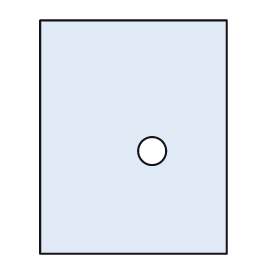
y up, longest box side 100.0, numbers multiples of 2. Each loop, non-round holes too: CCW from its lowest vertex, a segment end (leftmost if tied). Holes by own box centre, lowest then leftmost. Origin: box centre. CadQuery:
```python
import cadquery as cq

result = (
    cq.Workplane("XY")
    .moveTo(-40.0, -50.0)
    .lineTo(40.0, -50.0)
    .lineTo(40.0, 50.0)
    .lineTo(-40.0, 50.0)
    .close()
    .moveTo(8.0, -6.0)
    .circle(6.0)
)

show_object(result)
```